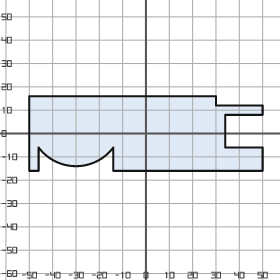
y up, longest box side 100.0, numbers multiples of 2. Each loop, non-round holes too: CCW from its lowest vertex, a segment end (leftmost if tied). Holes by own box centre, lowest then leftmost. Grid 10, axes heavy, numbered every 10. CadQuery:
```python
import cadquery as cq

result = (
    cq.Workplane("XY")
    .moveTo(-50.0, -16.0)
    .lineTo(-46.0, -16.0)
    .lineTo(-46.0, -6.0)
    .threePointArc((-30.0, -14.0), (-14.0, -6.0))
    .lineTo(-14.0, -16.0)
    .lineTo(50.0, -16.0)
    .lineTo(50.0, -6.0)
    .lineTo(34.0, -6.0)
    .lineTo(34.0, 8.0)
    .lineTo(50.0, 8.0)
    .lineTo(50.0, 12.0)
    .lineTo(30.0, 12.0)
    .lineTo(30.0, 16.0)
    .lineTo(-50.0, 16.0)
    .close()
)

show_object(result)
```